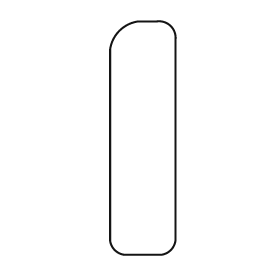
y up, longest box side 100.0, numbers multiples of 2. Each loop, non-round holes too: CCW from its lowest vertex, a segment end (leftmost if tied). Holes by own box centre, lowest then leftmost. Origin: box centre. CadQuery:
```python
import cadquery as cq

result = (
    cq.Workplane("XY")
    .moveTo(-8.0, -50.0)
    .lineTo(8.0, -50.0)
    .threePointArc((12.0, -48.0), (14.0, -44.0))
    .lineTo(14.0, 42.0)
    .threePointArc((12.0, 48.0), (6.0, 50.0))
    .lineTo(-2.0, 50.0)
    .threePointArc((-10.0, 46.0), (-14.0, 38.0))
    .lineTo(-14.0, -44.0)
    .threePointArc((-12.0, -48.0), (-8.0, -50.0))
    .close()
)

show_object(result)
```